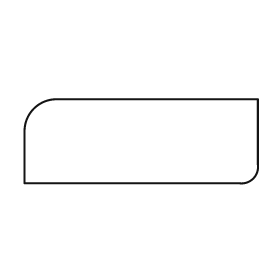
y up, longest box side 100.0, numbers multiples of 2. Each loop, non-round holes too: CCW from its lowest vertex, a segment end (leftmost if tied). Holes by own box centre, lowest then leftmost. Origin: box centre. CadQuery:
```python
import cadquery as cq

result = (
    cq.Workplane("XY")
    .moveTo(-50.0, -18.0)
    .lineTo(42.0, -18.0)
    .threePointArc((48.0, -16.0), (50.0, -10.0))
    .lineTo(50.0, 18.0)
    .lineTo(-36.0, 18.0)
    .threePointArc((-46.0, 14.0), (-50.0, 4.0))
    .close()
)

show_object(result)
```